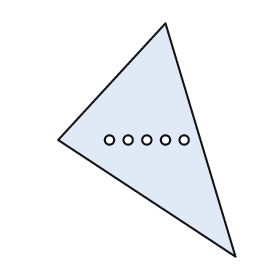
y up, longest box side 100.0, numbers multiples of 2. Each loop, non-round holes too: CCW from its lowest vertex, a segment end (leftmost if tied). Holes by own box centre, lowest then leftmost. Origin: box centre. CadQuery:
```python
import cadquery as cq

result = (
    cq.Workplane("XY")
    .moveTo(38.0, -50.0)
    .lineTo(8.0, 50.0)
    .lineTo(-38.0, 0.0)
    .close()
    .moveTo(-16.0, 0.0)
    .circle(2.0)
    .moveTo(-8.0, 0.0)
    .circle(2.0)
    .moveTo(0.0, 0.0)
    .circle(2.0)
    .moveTo(8.0, 0.0)
    .circle(2.0)
    .moveTo(16.0, 0.0)
    .circle(2.0)
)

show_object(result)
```